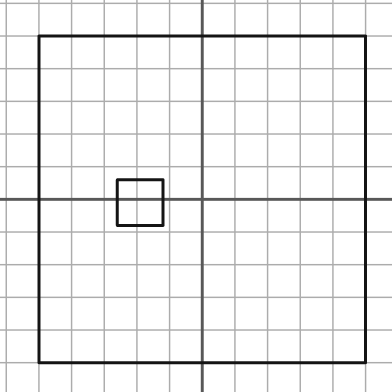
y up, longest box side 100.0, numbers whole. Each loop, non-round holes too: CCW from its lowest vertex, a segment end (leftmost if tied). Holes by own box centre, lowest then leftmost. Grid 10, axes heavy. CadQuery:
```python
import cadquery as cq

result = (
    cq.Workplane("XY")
    .moveTo(-50.0, -50.0)
    .lineTo(50.0, -50.0)
    .lineTo(50.0, 50.0)
    .lineTo(-50.0, 50.0)
    .close()
    .moveTo(-26.0, -8.0)
    .lineTo(-12.0, -8.0)
    .lineTo(-12.0, 6.0)
    .lineTo(-26.0, 6.0)
    .close()
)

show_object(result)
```